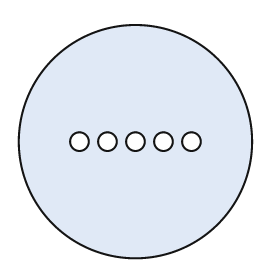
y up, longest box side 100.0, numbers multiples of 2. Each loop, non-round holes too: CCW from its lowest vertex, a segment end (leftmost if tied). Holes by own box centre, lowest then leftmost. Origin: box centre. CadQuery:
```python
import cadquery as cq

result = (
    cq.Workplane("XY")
    .moveTo(0.0, 0.0)
    .circle(50.0)
    .moveTo(-24.0, 0.0)
    .circle(4.0)
    .moveTo(-12.0, 0.0)
    .circle(4.0)
    .moveTo(0.0, 0.0)
    .circle(4.0)
    .moveTo(12.0, 0.0)
    .circle(4.0)
    .moveTo(24.0, 0.0)
    .circle(4.0)
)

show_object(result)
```